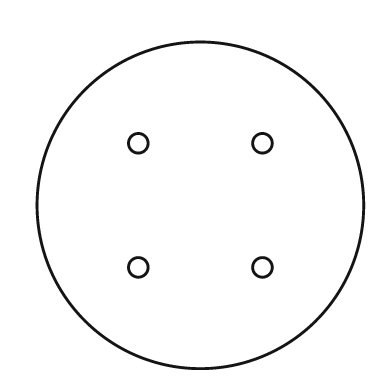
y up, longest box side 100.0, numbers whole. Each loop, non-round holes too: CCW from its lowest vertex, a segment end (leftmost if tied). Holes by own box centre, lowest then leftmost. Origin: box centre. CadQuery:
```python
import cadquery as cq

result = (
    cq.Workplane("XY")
    .moveTo(0.0, 0.0)
    .circle(50.0)
    .moveTo(-19.0, -19.0)
    .circle(3.0)
    .moveTo(19.0, -19.0)
    .circle(3.0)
    .moveTo(-19.0, 19.0)
    .circle(3.0)
    .moveTo(19.0, 19.0)
    .circle(3.0)
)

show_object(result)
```